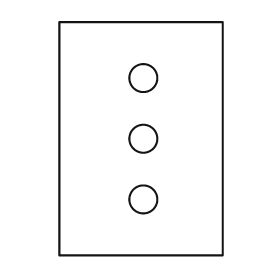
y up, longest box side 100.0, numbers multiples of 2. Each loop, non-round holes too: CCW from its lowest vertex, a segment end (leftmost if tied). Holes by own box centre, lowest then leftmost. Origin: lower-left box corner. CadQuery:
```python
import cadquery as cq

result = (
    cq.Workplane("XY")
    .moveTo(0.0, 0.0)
    .lineTo(70.0, 0.0)
    .lineTo(70.0, 100.0)
    .lineTo(0.0, 100.0)
    .close()
    .moveTo(36.0, 24.0)
    .circle(6.0)
    .moveTo(36.0, 50.0)
    .circle(6.0)
    .moveTo(36.0, 76.0)
    .circle(6.0)
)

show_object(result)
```